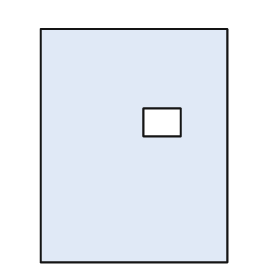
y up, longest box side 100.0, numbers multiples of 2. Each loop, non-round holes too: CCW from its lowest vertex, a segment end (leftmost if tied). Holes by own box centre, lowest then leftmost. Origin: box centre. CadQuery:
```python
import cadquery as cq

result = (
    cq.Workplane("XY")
    .moveTo(-40.0, -50.0)
    .lineTo(40.0, -50.0)
    .lineTo(40.0, 50.0)
    .lineTo(-40.0, 50.0)
    .close()
    .moveTo(4.0, 4.0)
    .lineTo(20.0, 4.0)
    .lineTo(20.0, 16.0)
    .lineTo(4.0, 16.0)
    .close()
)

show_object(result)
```